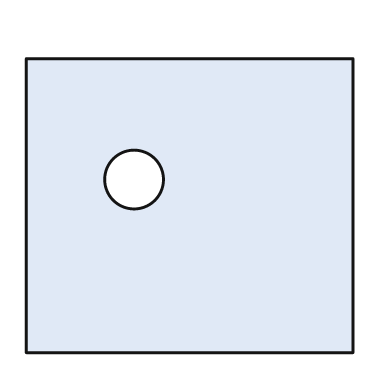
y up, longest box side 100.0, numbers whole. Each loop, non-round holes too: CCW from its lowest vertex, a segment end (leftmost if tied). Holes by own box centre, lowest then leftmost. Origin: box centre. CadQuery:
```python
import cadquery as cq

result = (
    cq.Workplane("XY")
    .moveTo(-50.0, -45.0)
    .lineTo(50.0, -45.0)
    .lineTo(50.0, 45.0)
    .lineTo(-50.0, 45.0)
    .close()
    .moveTo(-17.0, 8.0)
    .circle(9.0)
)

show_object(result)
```